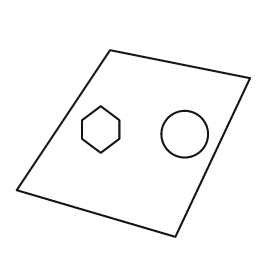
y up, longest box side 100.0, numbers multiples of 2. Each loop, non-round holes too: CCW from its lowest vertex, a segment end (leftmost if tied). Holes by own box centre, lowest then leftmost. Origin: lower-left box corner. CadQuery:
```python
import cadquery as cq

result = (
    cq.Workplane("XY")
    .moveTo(68.0, 0.0)
    .lineTo(100.0, 68.0)
    .lineTo(40.0, 80.0)
    .lineTo(0.0, 20.0)
    .close()
    .moveTo(72.0, 44.0)
    .circle(10.0)
    .moveTo(36.0, 36.0)
    .lineTo(44.0, 42.0)
    .lineTo(44.0, 50.0)
    .lineTo(36.0, 56.0)
    .lineTo(28.0, 50.0)
    .lineTo(28.0, 42.0)
    .close()
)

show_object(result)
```